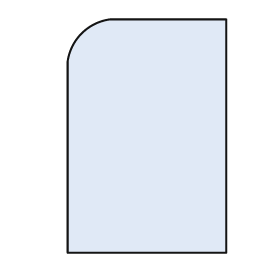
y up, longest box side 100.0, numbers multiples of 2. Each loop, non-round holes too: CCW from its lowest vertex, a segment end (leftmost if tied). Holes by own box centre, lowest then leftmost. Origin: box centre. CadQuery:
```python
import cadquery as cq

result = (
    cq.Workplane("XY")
    .moveTo(-34.0, -50.0)
    .lineTo(34.0, -50.0)
    .lineTo(34.0, 50.0)
    .lineTo(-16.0, 50.0)
    .threePointArc((-28.0, 44.0), (-34.0, 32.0))
    .close()
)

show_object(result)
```